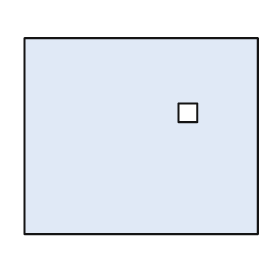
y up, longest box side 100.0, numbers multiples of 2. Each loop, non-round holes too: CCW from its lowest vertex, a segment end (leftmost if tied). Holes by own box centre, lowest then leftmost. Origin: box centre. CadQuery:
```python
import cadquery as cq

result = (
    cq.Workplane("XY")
    .moveTo(-50.0, -42.0)
    .lineTo(50.0, -42.0)
    .lineTo(50.0, 42.0)
    .lineTo(-50.0, 42.0)
    .close()
    .moveTo(16.0, 6.0)
    .lineTo(24.0, 6.0)
    .lineTo(24.0, 14.0)
    .lineTo(16.0, 14.0)
    .close()
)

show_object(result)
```